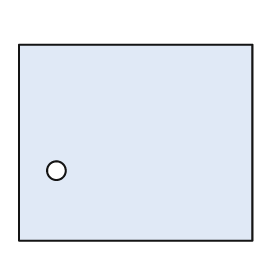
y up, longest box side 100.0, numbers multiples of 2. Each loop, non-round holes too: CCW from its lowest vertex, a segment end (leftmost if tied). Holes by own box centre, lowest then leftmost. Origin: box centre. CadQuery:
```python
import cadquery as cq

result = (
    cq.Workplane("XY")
    .moveTo(-50.0, -42.0)
    .lineTo(50.0, -42.0)
    .lineTo(50.0, 42.0)
    .lineTo(-50.0, 42.0)
    .close()
    .moveTo(-34.0, -12.0)
    .circle(4.0)
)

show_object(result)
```